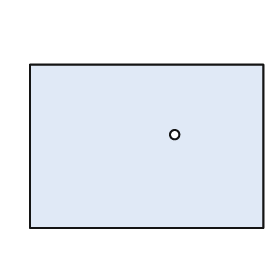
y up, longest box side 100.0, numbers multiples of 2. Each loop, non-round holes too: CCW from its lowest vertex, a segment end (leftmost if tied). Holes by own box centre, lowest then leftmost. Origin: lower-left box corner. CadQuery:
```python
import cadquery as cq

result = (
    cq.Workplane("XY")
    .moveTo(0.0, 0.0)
    .lineTo(100.0, 0.0)
    .lineTo(100.0, 70.0)
    .lineTo(0.0, 70.0)
    .close()
    .moveTo(62.0, 40.0)
    .circle(2.0)
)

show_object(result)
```